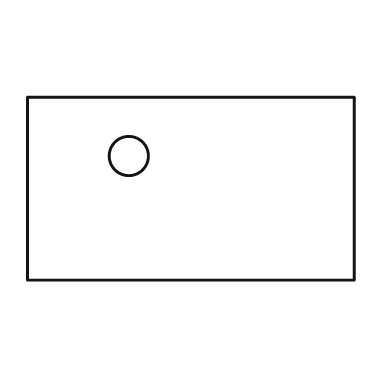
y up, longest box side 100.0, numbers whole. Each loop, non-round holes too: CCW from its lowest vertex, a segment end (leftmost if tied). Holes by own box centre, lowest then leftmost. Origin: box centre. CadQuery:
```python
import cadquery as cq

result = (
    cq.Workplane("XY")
    .moveTo(-50.0, -28.0)
    .lineTo(50.0, -28.0)
    .lineTo(50.0, 28.0)
    .lineTo(-50.0, 28.0)
    .close()
    .moveTo(-19.0, 10.0)
    .circle(6.0)
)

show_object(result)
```